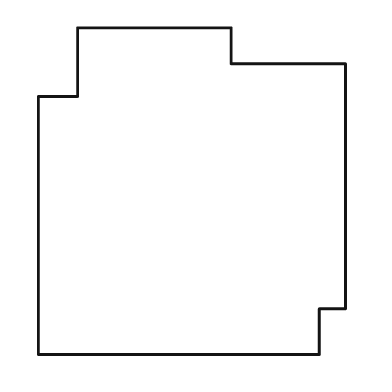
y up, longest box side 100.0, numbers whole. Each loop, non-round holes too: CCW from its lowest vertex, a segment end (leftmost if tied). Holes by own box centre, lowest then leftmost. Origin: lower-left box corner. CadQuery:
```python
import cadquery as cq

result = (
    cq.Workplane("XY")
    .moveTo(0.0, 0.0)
    .lineTo(86.0, 0.0)
    .lineTo(86.0, 14.0)
    .lineTo(94.0, 14.0)
    .lineTo(94.0, 89.0)
    .lineTo(59.0, 89.0)
    .lineTo(59.0, 100.0)
    .lineTo(12.0, 100.0)
    .lineTo(12.0, 79.0)
    .lineTo(0.0, 79.0)
    .close()
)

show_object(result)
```